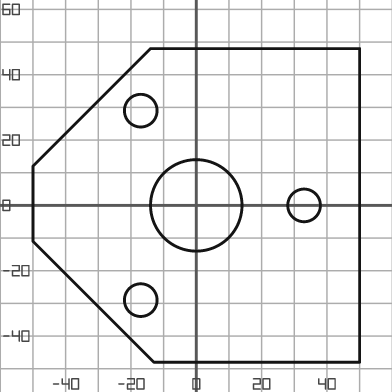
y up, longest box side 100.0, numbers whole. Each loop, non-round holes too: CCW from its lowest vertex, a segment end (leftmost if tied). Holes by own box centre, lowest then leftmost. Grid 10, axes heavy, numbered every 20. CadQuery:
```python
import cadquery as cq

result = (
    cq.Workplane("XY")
    .moveTo(-13.0, -48.0)
    .lineTo(50.0, -48.0)
    .lineTo(50.0, 48.0)
    .lineTo(-14.0, 48.0)
    .lineTo(-50.0, 12.0)
    .lineTo(-50.0, -11.0)
    .close()
    .moveTo(-17.0, -29.0)
    .circle(5.0)
    .moveTo(0.0, 0.0)
    .circle(14.0)
    .moveTo(33.0, 0.0)
    .circle(5.0)
    .moveTo(-17.0, 29.0)
    .circle(5.0)
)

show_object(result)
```